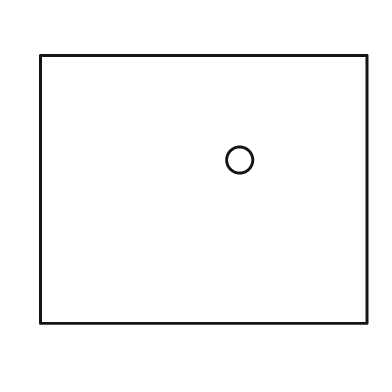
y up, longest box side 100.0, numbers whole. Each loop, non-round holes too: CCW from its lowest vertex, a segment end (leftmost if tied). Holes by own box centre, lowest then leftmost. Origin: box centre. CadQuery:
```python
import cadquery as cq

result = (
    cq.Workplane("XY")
    .moveTo(-50.0, -41.0)
    .lineTo(50.0, -41.0)
    .lineTo(50.0, 41.0)
    .lineTo(-50.0, 41.0)
    .close()
    .moveTo(11.0, 9.0)
    .circle(4.0)
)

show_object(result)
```